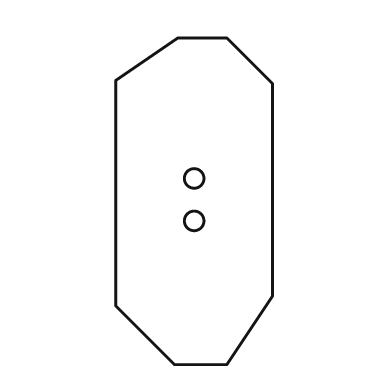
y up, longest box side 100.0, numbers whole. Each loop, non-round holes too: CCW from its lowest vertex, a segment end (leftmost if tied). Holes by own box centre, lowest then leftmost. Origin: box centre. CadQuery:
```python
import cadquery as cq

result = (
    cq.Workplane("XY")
    .moveTo(-6.0, -50.0)
    .lineTo(10.0, -50.0)
    .lineTo(24.0, -29.0)
    .lineTo(24.0, 36.0)
    .lineTo(10.0, 50.0)
    .lineTo(-5.0, 50.0)
    .lineTo(-24.0, 37.0)
    .lineTo(-24.0, -32.0)
    .close()
    .moveTo(0.0, -6.0)
    .circle(3.0)
    .moveTo(0.0, 7.0)
    .circle(3.0)
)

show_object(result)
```